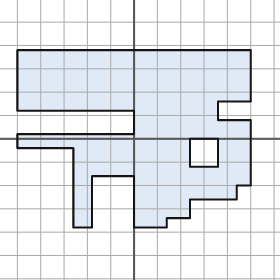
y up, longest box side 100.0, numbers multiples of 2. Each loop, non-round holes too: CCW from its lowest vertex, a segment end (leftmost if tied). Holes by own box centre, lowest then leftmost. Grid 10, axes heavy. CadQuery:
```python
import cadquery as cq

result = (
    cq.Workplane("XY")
    .moveTo(-26.0, -38.0)
    .lineTo(-18.0, -38.0)
    .lineTo(-18.0, -16.0)
    .lineTo(0.0, -16.0)
    .lineTo(0.0, -38.0)
    .lineTo(14.0, -38.0)
    .lineTo(14.0, -34.0)
    .lineTo(24.0, -34.0)
    .lineTo(24.0, -26.0)
    .lineTo(44.0, -26.0)
    .lineTo(44.0, -20.0)
    .lineTo(50.0, -20.0)
    .lineTo(50.0, 8.0)
    .lineTo(36.0, 8.0)
    .lineTo(36.0, 16.0)
    .lineTo(50.0, 16.0)
    .lineTo(50.0, 38.0)
    .lineTo(-50.0, 38.0)
    .lineTo(-50.0, 12.0)
    .lineTo(0.0, 12.0)
    .lineTo(0.0, 2.0)
    .lineTo(-50.0, 2.0)
    .lineTo(-50.0, -4.0)
    .lineTo(-26.0, -4.0)
    .close()
    .moveTo(24.0, -12.0)
    .lineTo(36.0, -12.0)
    .lineTo(36.0, 0.0)
    .lineTo(24.0, 0.0)
    .close()
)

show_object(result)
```